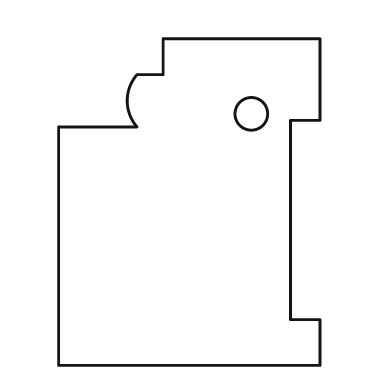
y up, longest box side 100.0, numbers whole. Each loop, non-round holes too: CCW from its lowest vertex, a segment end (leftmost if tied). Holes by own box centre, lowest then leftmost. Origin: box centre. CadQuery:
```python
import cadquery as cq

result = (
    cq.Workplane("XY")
    .moveTo(-40.0, -50.0)
    .lineTo(40.0, -50.0)
    .lineTo(40.0, -36.0)
    .lineTo(31.0, -36.0)
    .lineTo(31.0, 25.0)
    .lineTo(40.0, 25.0)
    .lineTo(40.0, 50.0)
    .lineTo(-8.0, 50.0)
    .lineTo(-8.0, 39.0)
    .lineTo(-16.0, 39.0)
    .threePointArc((-19.0, 31.0), (-16.0, 23.0))
    .lineTo(-40.0, 23.0)
    .close()
    .moveTo(19.0, 27.0)
    .circle(5.0)
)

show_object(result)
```